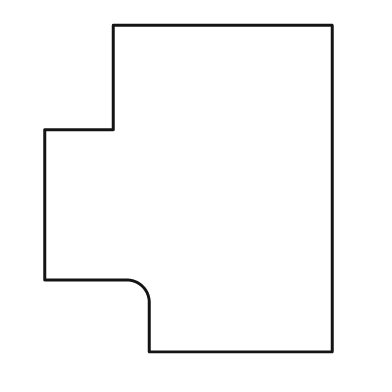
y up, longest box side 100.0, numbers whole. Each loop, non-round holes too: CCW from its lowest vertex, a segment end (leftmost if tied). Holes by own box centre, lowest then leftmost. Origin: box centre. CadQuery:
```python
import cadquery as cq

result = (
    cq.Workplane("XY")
    .moveTo(-12.0, -50.0)
    .lineTo(44.0, -50.0)
    .lineTo(44.0, 50.0)
    .lineTo(-23.0, 50.0)
    .lineTo(-23.0, 18.0)
    .lineTo(-44.0, 18.0)
    .lineTo(-44.0, -28.0)
    .lineTo(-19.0, -28.0)
    .threePointArc((-14.0, -30.0), (-12.0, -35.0))
    .close()
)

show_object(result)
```